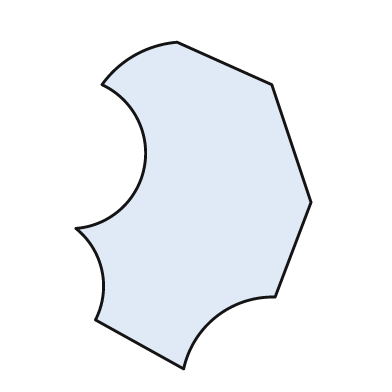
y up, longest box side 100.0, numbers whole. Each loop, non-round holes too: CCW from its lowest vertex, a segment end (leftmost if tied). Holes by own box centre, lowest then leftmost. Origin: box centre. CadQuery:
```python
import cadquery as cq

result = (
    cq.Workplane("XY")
    .moveTo(-3.0, -50.0)
    .threePointArc((7.0, -34.0), (25.0, -28.0))
    .lineTo(36.0, 1.0)
    .lineTo(24.0, 37.0)
    .lineTo(-5.0, 50.0)
    .threePointArc((-18.0, 46.0), (-28.0, 37.0))
    .threePointArc((-15.0, 12.0), (-36.0, -7.0))
    .threePointArc((-28.0, -20.0), (-30.0, -35.0))
    .close()
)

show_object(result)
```